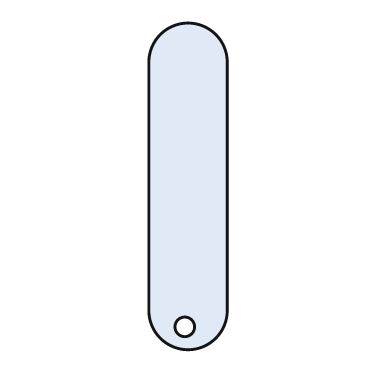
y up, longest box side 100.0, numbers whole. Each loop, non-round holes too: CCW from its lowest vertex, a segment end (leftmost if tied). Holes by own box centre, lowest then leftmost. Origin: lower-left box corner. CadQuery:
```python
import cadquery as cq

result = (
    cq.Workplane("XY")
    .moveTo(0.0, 12.0)
    .threePointArc((12.0, 0.0), (24.0, 12.0))
    .lineTo(24.0, 88.0)
    .threePointArc((12.0, 100.0), (0.0, 88.0))
    .close()
    .moveTo(11.0, 7.0)
    .circle(3.0)
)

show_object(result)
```